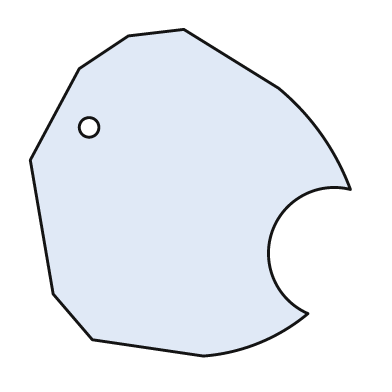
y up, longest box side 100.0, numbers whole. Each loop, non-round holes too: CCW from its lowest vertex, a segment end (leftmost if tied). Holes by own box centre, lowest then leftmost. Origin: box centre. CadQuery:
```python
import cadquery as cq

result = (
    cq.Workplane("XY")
    .moveTo(4.0, -50.0)
    .threePointArc((21.0, -46.0), (36.0, -37.0))
    .threePointArc((25.0, -12.0), (49.0, 1.0))
    .threePointArc((40.0, 18.0), (27.0, 32.0))
    .lineTo(-2.0, 50.0)
    .lineTo(-19.0, 48.0)
    .lineTo(-34.0, 38.0)
    .lineTo(-49.0, 10.0)
    .lineTo(-42.0, -31.0)
    .lineTo(-30.0, -45.0)
    .close()
    .moveTo(-31.0, 20.0)
    .circle(3.0)
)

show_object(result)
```